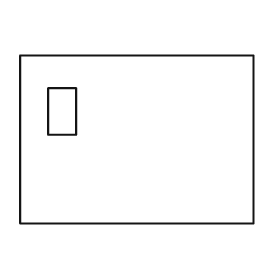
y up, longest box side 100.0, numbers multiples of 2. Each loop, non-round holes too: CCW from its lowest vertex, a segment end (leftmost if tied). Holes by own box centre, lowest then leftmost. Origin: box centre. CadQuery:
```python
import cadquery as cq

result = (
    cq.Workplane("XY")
    .moveTo(-50.0, -36.0)
    .lineTo(50.0, -36.0)
    .lineTo(50.0, 36.0)
    .lineTo(-50.0, 36.0)
    .close()
    .moveTo(-38.0, 2.0)
    .lineTo(-26.0, 2.0)
    .lineTo(-26.0, 22.0)
    .lineTo(-38.0, 22.0)
    .close()
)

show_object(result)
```